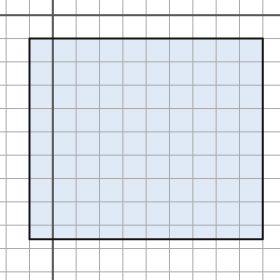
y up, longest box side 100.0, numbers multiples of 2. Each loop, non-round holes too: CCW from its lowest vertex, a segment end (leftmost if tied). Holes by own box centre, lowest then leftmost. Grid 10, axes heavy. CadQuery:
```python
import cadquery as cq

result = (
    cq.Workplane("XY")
    .moveTo(-10.0, -96.0)
    .lineTo(90.0, -96.0)
    .lineTo(90.0, -10.0)
    .lineTo(-10.0, -10.0)
    .close()
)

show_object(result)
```